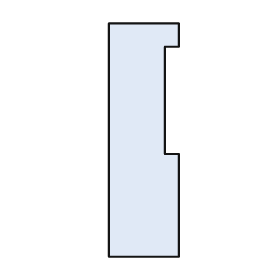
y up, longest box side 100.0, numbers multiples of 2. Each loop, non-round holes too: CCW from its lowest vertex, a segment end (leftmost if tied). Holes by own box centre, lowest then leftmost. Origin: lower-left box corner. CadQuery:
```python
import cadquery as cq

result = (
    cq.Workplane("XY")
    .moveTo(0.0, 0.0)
    .lineTo(30.0, 0.0)
    .lineTo(30.0, 44.0)
    .lineTo(24.0, 44.0)
    .lineTo(24.0, 90.0)
    .lineTo(30.0, 90.0)
    .lineTo(30.0, 100.0)
    .lineTo(0.0, 100.0)
    .close()
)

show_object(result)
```